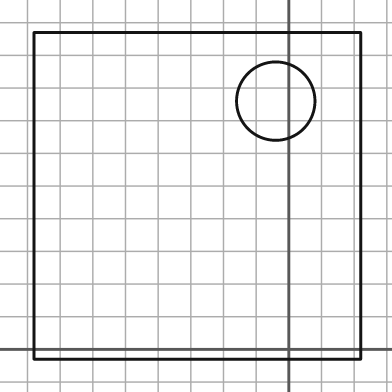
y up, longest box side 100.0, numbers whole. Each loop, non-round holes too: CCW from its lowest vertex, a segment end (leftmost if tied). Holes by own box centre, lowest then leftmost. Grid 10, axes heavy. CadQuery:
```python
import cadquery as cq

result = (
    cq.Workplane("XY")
    .moveTo(-78.0, -3.0)
    .lineTo(22.0, -3.0)
    .lineTo(22.0, 97.0)
    .lineTo(-78.0, 97.0)
    .close()
    .moveTo(-4.0, 76.0)
    .circle(12.0)
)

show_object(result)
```